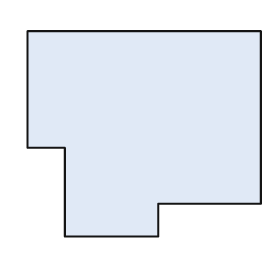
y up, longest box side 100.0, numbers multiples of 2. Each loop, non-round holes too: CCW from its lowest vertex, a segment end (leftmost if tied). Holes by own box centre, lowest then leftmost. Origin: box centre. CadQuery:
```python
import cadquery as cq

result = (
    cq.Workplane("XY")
    .moveTo(-34.0, -44.0)
    .lineTo(6.0, -44.0)
    .lineTo(6.0, -30.0)
    .lineTo(50.0, -30.0)
    .lineTo(50.0, 44.0)
    .lineTo(-50.0, 44.0)
    .lineTo(-50.0, -6.0)
    .lineTo(-34.0, -6.0)
    .close()
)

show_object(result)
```